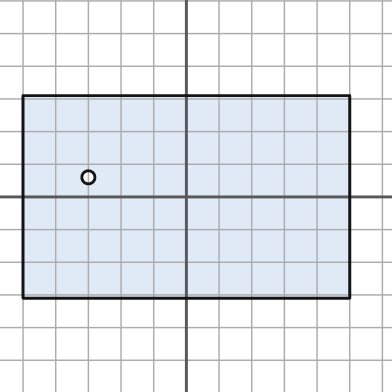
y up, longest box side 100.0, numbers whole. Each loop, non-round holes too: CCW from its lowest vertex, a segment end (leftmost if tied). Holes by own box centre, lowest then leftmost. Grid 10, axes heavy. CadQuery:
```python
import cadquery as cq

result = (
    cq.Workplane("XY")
    .moveTo(-50.0, -31.0)
    .lineTo(50.0, -31.0)
    .lineTo(50.0, 31.0)
    .lineTo(-50.0, 31.0)
    .close()
    .moveTo(-30.0, 6.0)
    .circle(2.0)
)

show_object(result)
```